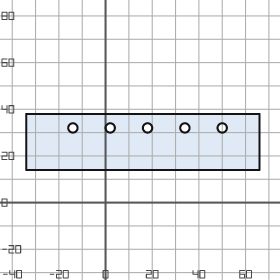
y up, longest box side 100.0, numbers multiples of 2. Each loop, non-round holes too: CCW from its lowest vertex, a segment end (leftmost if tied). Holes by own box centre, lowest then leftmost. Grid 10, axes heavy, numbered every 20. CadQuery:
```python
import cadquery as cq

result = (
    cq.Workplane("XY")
    .moveTo(-34.0, 14.0)
    .lineTo(66.0, 14.0)
    .lineTo(66.0, 38.0)
    .lineTo(-34.0, 38.0)
    .close()
    .moveTo(-14.0, 32.0)
    .circle(2.0)
    .moveTo(2.0, 32.0)
    .circle(2.0)
    .moveTo(18.0, 32.0)
    .circle(2.0)
    .moveTo(34.0, 32.0)
    .circle(2.0)
    .moveTo(50.0, 32.0)
    .circle(2.0)
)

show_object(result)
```